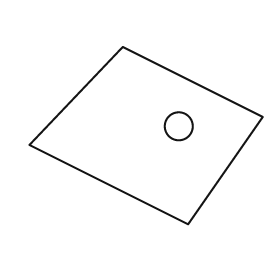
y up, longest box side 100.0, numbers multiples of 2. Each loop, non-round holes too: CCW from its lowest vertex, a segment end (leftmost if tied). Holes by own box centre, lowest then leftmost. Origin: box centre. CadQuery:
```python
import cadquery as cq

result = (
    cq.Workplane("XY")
    .moveTo(18.0, -38.0)
    .lineTo(50.0, 8.0)
    .lineTo(-10.0, 38.0)
    .lineTo(-50.0, -4.0)
    .close()
    .moveTo(14.0, 4.0)
    .circle(6.0)
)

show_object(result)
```